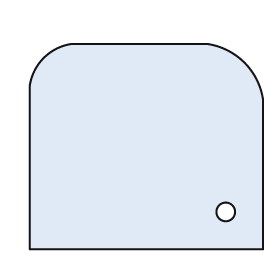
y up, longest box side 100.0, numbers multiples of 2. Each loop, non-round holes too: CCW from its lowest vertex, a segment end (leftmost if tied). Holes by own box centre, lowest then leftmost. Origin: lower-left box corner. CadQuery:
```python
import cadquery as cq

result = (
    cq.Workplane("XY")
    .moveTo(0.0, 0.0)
    .lineTo(100.0, 0.0)
    .lineTo(100.0, 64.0)
    .threePointArc((92.0, 80.0), (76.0, 88.0))
    .lineTo(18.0, 88.0)
    .threePointArc((6.0, 82.0), (0.0, 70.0))
    .close()
    .moveTo(84.0, 16.0)
    .circle(4.0)
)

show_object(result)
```